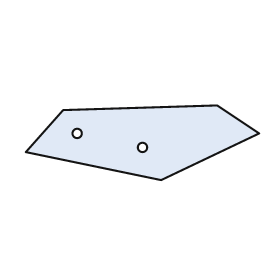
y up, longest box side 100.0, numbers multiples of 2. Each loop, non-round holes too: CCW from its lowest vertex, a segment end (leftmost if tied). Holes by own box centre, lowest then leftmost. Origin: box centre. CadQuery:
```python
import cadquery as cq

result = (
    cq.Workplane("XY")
    .moveTo(8.0, -16.0)
    .lineTo(50.0, 4.0)
    .lineTo(32.0, 16.0)
    .lineTo(-34.0, 14.0)
    .lineTo(-50.0, -4.0)
    .close()
    .moveTo(0.0, -2.0)
    .circle(2.0)
    .moveTo(-28.0, 4.0)
    .circle(2.0)
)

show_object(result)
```